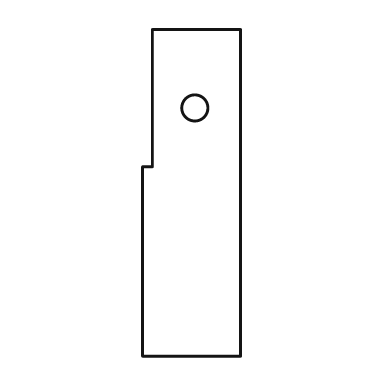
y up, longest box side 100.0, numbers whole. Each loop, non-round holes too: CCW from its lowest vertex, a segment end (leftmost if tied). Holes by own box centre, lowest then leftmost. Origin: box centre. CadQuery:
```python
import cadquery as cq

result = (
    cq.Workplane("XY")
    .moveTo(-15.0, -50.0)
    .lineTo(15.0, -50.0)
    .lineTo(15.0, 50.0)
    .lineTo(-12.0, 50.0)
    .lineTo(-12.0, 8.0)
    .lineTo(-15.0, 8.0)
    .close()
    .moveTo(1.0, 26.0)
    .circle(4.0)
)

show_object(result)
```